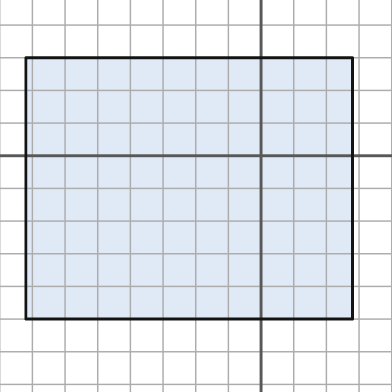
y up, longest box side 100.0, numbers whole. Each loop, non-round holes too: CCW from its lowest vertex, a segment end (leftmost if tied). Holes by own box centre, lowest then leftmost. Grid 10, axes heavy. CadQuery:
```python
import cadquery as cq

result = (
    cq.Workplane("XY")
    .moveTo(-72.0, -50.0)
    .lineTo(28.0, -50.0)
    .lineTo(28.0, 30.0)
    .lineTo(-72.0, 30.0)
    .close()
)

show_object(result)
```